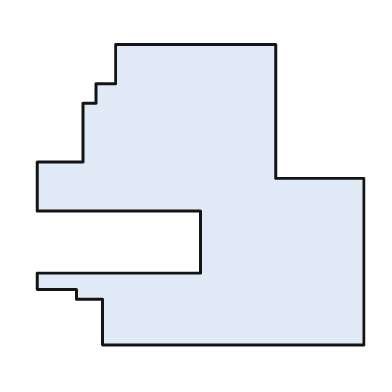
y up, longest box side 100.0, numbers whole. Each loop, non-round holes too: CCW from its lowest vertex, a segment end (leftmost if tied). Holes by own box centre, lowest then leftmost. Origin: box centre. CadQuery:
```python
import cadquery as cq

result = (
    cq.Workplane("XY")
    .moveTo(-30.0, -46.0)
    .lineTo(50.0, -46.0)
    .lineTo(50.0, 5.0)
    .lineTo(23.0, 5.0)
    .lineTo(23.0, 46.0)
    .lineTo(-26.0, 46.0)
    .lineTo(-26.0, 34.0)
    .lineTo(-32.0, 34.0)
    .lineTo(-32.0, 28.0)
    .lineTo(-36.0, 28.0)
    .lineTo(-36.0, 10.0)
    .lineTo(-50.0, 10.0)
    .lineTo(-50.0, -5.0)
    .lineTo(0.0, -5.0)
    .lineTo(0.0, -24.0)
    .lineTo(-50.0, -24.0)
    .lineTo(-50.0, -29.0)
    .lineTo(-38.0, -29.0)
    .lineTo(-38.0, -32.0)
    .lineTo(-30.0, -32.0)
    .close()
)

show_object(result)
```